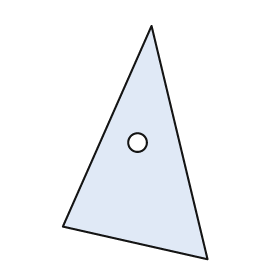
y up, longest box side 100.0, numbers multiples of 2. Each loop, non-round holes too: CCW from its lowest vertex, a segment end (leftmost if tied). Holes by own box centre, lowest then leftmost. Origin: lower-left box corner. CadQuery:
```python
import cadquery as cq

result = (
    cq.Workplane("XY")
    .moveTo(62.0, 0.0)
    .lineTo(38.0, 100.0)
    .lineTo(0.0, 14.0)
    .close()
    .moveTo(32.0, 50.0)
    .circle(4.0)
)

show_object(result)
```